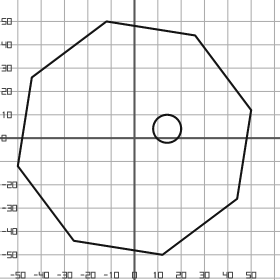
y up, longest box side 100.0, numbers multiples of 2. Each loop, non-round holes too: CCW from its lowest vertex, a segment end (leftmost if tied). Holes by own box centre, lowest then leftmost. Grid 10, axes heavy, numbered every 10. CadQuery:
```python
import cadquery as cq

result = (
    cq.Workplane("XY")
    .moveTo(12.0, -50.0)
    .lineTo(44.0, -26.0)
    .lineTo(50.0, 12.0)
    .lineTo(26.0, 44.0)
    .lineTo(-12.0, 50.0)
    .lineTo(-44.0, 26.0)
    .lineTo(-50.0, -12.0)
    .lineTo(-26.0, -44.0)
    .close()
    .moveTo(14.0, 4.0)
    .circle(6.0)
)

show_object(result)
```